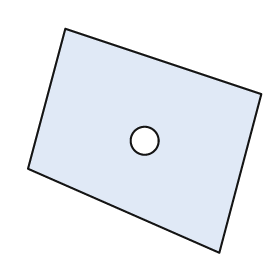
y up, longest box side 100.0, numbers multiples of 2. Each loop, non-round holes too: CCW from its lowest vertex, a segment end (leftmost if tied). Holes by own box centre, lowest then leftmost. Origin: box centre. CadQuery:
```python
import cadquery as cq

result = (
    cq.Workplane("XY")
    .moveTo(32.0, -48.0)
    .lineTo(50.0, 20.0)
    .lineTo(-34.0, 48.0)
    .lineTo(-50.0, -12.0)
    .close()
    .moveTo(0.0, 0.0)
    .circle(6.0)
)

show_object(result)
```